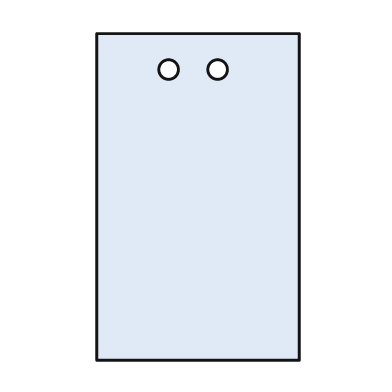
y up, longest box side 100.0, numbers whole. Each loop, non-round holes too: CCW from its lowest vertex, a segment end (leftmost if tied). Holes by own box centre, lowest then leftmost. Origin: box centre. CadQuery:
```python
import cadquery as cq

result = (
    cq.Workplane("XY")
    .moveTo(-31.0, -50.0)
    .lineTo(31.0, -50.0)
    .lineTo(31.0, 50.0)
    .lineTo(-31.0, 50.0)
    .close()
    .moveTo(-9.0, 39.0)
    .circle(3.0)
    .moveTo(6.0, 39.0)
    .circle(3.0)
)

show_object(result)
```